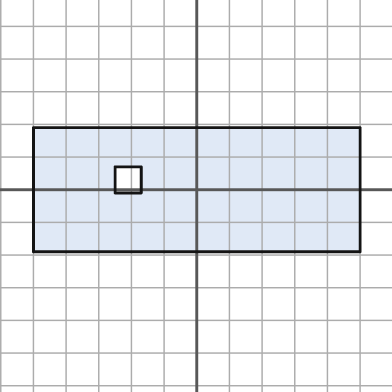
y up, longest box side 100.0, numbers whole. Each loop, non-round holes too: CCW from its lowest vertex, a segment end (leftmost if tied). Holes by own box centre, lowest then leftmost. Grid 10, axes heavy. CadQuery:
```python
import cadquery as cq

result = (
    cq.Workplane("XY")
    .moveTo(-50.0, -19.0)
    .lineTo(50.0, -19.0)
    .lineTo(50.0, 19.0)
    .lineTo(-50.0, 19.0)
    .close()
    .moveTo(-25.0, -1.0)
    .lineTo(-17.0, -1.0)
    .lineTo(-17.0, 7.0)
    .lineTo(-25.0, 7.0)
    .close()
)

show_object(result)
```